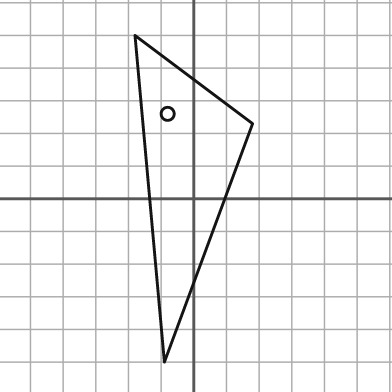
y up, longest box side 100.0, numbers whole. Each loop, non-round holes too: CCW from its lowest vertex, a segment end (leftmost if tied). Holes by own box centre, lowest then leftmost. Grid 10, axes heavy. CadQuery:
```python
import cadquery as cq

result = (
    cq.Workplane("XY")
    .moveTo(-9.0, -50.0)
    .lineTo(18.0, 23.0)
    .lineTo(-18.0, 50.0)
    .close()
    .moveTo(-8.0, 26.0)
    .circle(2.0)
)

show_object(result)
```